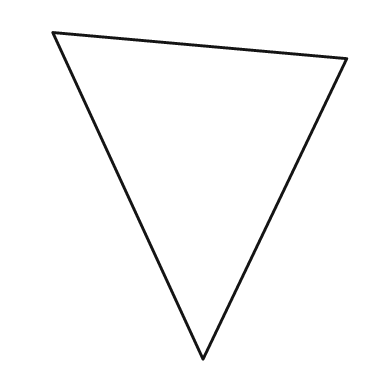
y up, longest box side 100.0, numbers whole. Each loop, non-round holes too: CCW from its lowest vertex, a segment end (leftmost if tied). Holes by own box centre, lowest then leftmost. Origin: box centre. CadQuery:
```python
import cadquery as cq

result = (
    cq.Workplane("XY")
    .moveTo(1.0, -50.0)
    .lineTo(45.0, 42.0)
    .lineTo(-45.0, 50.0)
    .close()
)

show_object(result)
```